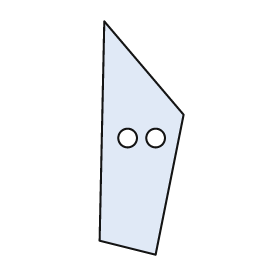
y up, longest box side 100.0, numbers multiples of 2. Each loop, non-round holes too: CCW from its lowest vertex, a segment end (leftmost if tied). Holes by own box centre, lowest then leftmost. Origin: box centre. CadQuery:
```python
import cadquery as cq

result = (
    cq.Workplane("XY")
    .moveTo(6.0, -50.0)
    .lineTo(18.0, 10.0)
    .lineTo(-16.0, 50.0)
    .lineTo(-18.0, -44.0)
    .close()
    .moveTo(-6.0, 0.0)
    .circle(4.0)
    .moveTo(6.0, 0.0)
    .circle(4.0)
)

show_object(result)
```